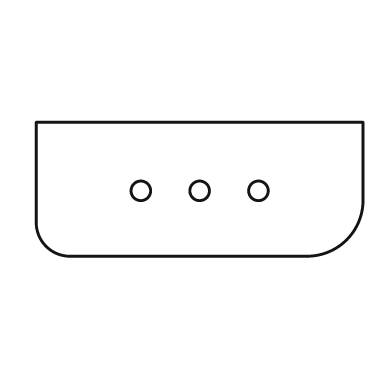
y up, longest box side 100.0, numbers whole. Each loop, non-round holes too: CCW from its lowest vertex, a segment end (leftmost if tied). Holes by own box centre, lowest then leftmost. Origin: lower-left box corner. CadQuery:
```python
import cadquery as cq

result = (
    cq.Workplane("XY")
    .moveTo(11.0, 0.0)
    .lineTo(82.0, 0.0)
    .threePointArc((95.0, 5.0), (100.0, 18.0))
    .lineTo(100.0, 41.0)
    .lineTo(0.0, 41.0)
    .lineTo(0.0, 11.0)
    .threePointArc((3.0, 3.0), (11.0, 0.0))
    .close()
    .moveTo(32.0, 20.0)
    .circle(3.0)
    .moveTo(50.0, 20.0)
    .circle(3.0)
    .moveTo(68.0, 20.0)
    .circle(3.0)
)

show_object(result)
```